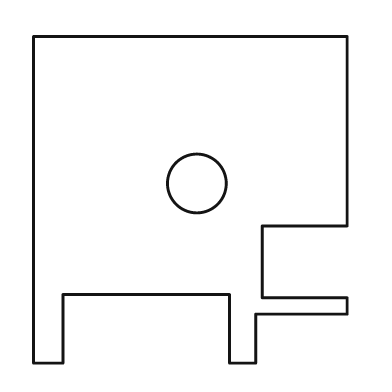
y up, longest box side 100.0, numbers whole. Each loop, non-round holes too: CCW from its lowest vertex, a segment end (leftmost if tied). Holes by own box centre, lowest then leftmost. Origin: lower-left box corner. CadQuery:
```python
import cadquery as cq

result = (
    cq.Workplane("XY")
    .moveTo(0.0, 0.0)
    .lineTo(9.0, 0.0)
    .lineTo(9.0, 21.0)
    .lineTo(60.0, 21.0)
    .lineTo(60.0, 0.0)
    .lineTo(68.0, 0.0)
    .lineTo(68.0, 15.0)
    .lineTo(96.0, 15.0)
    .lineTo(96.0, 20.0)
    .lineTo(70.0, 20.0)
    .lineTo(70.0, 42.0)
    .lineTo(96.0, 42.0)
    .lineTo(96.0, 100.0)
    .lineTo(0.0, 100.0)
    .close()
    .moveTo(50.0, 55.0)
    .circle(9.0)
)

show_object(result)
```